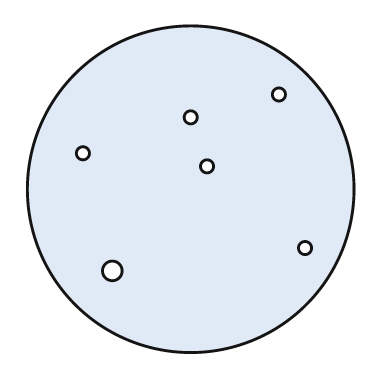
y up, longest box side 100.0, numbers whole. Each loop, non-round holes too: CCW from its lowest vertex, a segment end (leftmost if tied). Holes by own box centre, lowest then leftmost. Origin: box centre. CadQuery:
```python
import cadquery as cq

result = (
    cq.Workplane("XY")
    .moveTo(0.0, 0.0)
    .circle(50.0)
    .moveTo(-24.0, -25.0)
    .circle(3.0)
    .moveTo(35.0, -18.0)
    .circle(2.0)
    .moveTo(5.0, 7.0)
    .circle(2.0)
    .moveTo(-33.0, 11.0)
    .circle(2.0)
    .moveTo(0.0, 22.0)
    .circle(2.0)
    .moveTo(27.0, 29.0)
    .circle(2.0)
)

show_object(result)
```